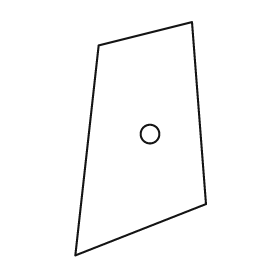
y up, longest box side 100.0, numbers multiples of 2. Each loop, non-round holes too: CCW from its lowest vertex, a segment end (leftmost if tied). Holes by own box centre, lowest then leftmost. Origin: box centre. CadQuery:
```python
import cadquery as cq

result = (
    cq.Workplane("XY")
    .moveTo(-28.0, -50.0)
    .lineTo(28.0, -28.0)
    .lineTo(22.0, 50.0)
    .lineTo(-18.0, 40.0)
    .close()
    .moveTo(4.0, 2.0)
    .circle(4.0)
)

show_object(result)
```